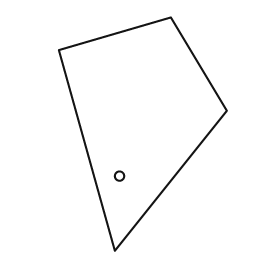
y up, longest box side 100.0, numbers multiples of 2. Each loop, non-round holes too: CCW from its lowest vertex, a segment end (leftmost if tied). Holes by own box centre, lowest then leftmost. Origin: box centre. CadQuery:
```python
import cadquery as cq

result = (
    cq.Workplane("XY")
    .moveTo(-12.0, -50.0)
    .lineTo(36.0, 10.0)
    .lineTo(12.0, 50.0)
    .lineTo(-36.0, 36.0)
    .close()
    .moveTo(-10.0, -18.0)
    .circle(2.0)
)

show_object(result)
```